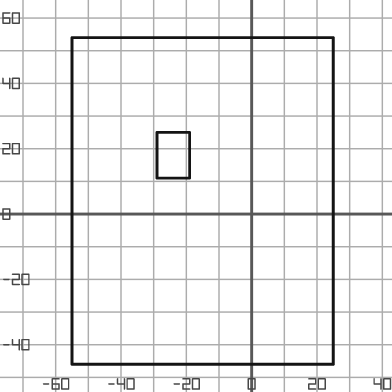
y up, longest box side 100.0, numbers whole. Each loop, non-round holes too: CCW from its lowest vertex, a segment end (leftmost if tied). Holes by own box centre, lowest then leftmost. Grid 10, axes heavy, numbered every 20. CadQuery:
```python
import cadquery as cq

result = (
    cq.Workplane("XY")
    .moveTo(-55.0, -46.0)
    .lineTo(25.0, -46.0)
    .lineTo(25.0, 54.0)
    .lineTo(-55.0, 54.0)
    .close()
    .moveTo(-29.0, 11.0)
    .lineTo(-19.0, 11.0)
    .lineTo(-19.0, 25.0)
    .lineTo(-29.0, 25.0)
    .close()
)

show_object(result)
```